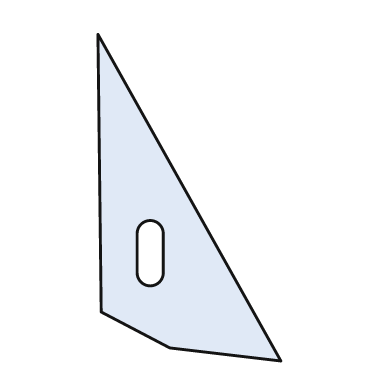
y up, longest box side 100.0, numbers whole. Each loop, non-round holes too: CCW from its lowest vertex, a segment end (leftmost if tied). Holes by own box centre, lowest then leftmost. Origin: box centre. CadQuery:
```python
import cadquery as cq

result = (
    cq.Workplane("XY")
    .moveTo(28.0, -50.0)
    .lineTo(-28.0, 50.0)
    .lineTo(-27.0, -35.0)
    .lineTo(-6.0, -46.0)
    .close()
    .moveTo(-16.0, -23.0)
    .threePointArc((-12.0, -27.0), (-8.0, -23.0))
    .lineTo(-8.0, -11.0)
    .threePointArc((-12.0, -7.0), (-16.0, -11.0))
    .close()
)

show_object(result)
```